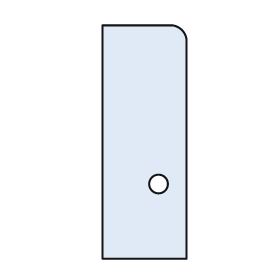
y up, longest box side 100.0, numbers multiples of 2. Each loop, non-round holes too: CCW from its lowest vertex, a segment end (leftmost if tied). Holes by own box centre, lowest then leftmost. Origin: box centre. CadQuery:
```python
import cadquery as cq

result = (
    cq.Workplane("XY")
    .moveTo(-18.0, -50.0)
    .lineTo(18.0, -50.0)
    .lineTo(18.0, 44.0)
    .threePointArc((16.0, 48.0), (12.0, 50.0))
    .lineTo(-18.0, 50.0)
    .close()
    .moveTo(6.0, -18.0)
    .circle(4.0)
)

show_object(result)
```